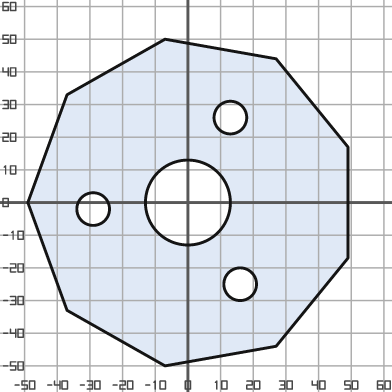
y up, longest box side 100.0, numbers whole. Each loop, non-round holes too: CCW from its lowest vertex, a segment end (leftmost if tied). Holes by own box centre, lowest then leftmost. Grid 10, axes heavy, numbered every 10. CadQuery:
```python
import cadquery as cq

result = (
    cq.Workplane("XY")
    .moveTo(-7.0, -50.0)
    .lineTo(27.0, -44.0)
    .lineTo(49.0, -17.0)
    .lineTo(49.0, 17.0)
    .lineTo(27.0, 44.0)
    .lineTo(-7.0, 50.0)
    .lineTo(-37.0, 33.0)
    .lineTo(-49.0, 0.0)
    .lineTo(-37.0, -33.0)
    .close()
    .moveTo(16.0, -25.0)
    .circle(5.0)
    .moveTo(-29.0, -2.0)
    .circle(5.0)
    .moveTo(0.0, 0.0)
    .circle(13.0)
    .moveTo(13.0, 26.0)
    .circle(5.0)
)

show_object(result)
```